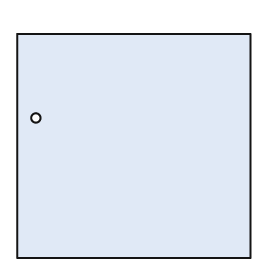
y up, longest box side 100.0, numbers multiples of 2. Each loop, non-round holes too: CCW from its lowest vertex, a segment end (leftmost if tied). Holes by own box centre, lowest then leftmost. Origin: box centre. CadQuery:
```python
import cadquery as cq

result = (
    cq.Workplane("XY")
    .moveTo(-50.0, -48.0)
    .lineTo(50.0, -48.0)
    .lineTo(50.0, 48.0)
    .lineTo(-50.0, 48.0)
    .close()
    .moveTo(-42.0, 12.0)
    .circle(2.0)
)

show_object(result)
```